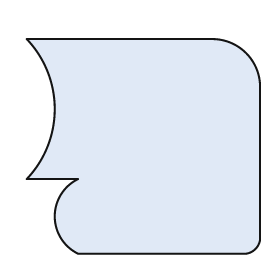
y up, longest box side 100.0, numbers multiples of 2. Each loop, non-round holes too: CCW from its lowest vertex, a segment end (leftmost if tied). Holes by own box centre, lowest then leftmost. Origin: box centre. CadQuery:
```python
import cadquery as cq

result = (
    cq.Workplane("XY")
    .moveTo(-28.0, -46.0)
    .lineTo(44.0, -46.0)
    .threePointArc((48.0, -44.0), (50.0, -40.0))
    .lineTo(50.0, 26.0)
    .threePointArc((44.0, 40.0), (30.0, 46.0))
    .lineTo(-50.0, 46.0)
    .threePointArc((-38.0, 16.0), (-50.0, -14.0))
    .lineTo(-28.0, -14.0)
    .threePointArc((-38.0, -30.0), (-28.0, -46.0))
    .close()
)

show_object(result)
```